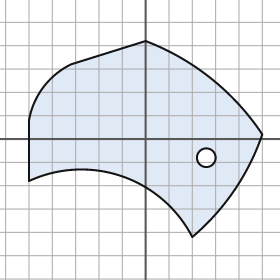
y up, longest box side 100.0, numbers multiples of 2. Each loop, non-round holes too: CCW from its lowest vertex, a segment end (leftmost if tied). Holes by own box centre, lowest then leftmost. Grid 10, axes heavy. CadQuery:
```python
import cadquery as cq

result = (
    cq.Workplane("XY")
    .moveTo(20.0, -42.0)
    .threePointArc((38.0, -22.0), (50.0, 2.0))
    .threePointArc((28.0, 26.0), (0.0, 42.0))
    .lineTo(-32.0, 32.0)
    .threePointArc((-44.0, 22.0), (-50.0, 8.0))
    .lineTo(-50.0, -18.0)
    .threePointArc((-10.0, -16.0), (20.0, -42.0))
    .close()
    .moveTo(26.0, -8.0)
    .circle(4.0)
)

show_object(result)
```